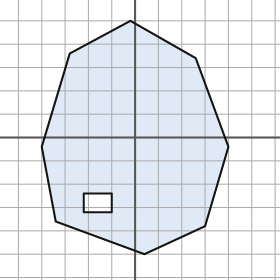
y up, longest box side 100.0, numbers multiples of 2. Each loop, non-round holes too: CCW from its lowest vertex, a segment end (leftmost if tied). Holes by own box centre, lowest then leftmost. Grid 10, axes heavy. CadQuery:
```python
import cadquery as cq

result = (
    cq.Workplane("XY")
    .moveTo(4.0, -50.0)
    .lineTo(30.0, -38.0)
    .lineTo(40.0, -4.0)
    .lineTo(26.0, 34.0)
    .lineTo(-2.0, 50.0)
    .lineTo(-28.0, 36.0)
    .lineTo(-40.0, -4.0)
    .lineTo(-34.0, -36.0)
    .close()
    .moveTo(-22.0, -32.0)
    .lineTo(-10.0, -32.0)
    .lineTo(-10.0, -24.0)
    .lineTo(-22.0, -24.0)
    .close()
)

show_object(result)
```